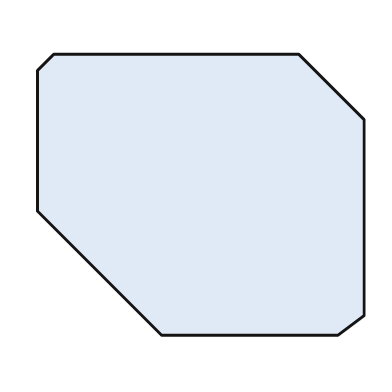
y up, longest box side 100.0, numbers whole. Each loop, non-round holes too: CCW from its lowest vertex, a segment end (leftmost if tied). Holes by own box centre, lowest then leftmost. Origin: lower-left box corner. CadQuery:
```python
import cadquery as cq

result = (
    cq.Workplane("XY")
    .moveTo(38.0, 0.0)
    .lineTo(92.0, 0.0)
    .lineTo(100.0, 6.0)
    .lineTo(100.0, 66.0)
    .lineTo(80.0, 86.0)
    .lineTo(5.0, 86.0)
    .lineTo(0.0, 81.0)
    .lineTo(0.0, 38.0)
    .close()
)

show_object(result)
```